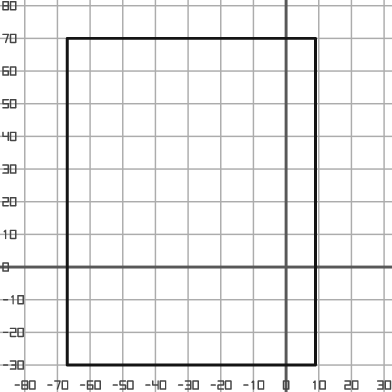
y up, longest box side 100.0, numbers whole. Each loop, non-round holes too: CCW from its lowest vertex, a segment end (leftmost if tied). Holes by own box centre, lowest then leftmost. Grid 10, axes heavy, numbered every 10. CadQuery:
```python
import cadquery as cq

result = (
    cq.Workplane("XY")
    .moveTo(-67.0, -30.0)
    .lineTo(9.0, -30.0)
    .lineTo(9.0, 70.0)
    .lineTo(-67.0, 70.0)
    .close()
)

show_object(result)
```